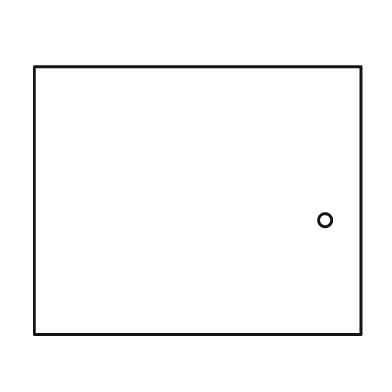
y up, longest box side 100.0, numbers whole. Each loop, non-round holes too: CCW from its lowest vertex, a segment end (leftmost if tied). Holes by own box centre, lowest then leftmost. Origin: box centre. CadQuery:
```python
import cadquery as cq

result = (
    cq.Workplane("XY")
    .moveTo(-50.0, -41.0)
    .lineTo(50.0, -41.0)
    .lineTo(50.0, 41.0)
    .lineTo(-50.0, 41.0)
    .close()
    .moveTo(39.0, -6.0)
    .circle(2.0)
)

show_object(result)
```